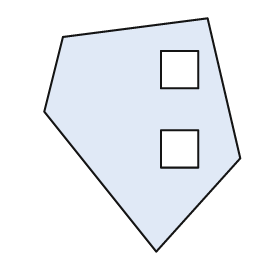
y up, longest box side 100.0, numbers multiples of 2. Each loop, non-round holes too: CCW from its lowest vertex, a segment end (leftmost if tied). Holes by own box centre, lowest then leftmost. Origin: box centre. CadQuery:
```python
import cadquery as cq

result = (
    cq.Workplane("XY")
    .moveTo(6.0, -50.0)
    .lineTo(42.0, -10.0)
    .lineTo(28.0, 50.0)
    .lineTo(-34.0, 42.0)
    .lineTo(-42.0, 10.0)
    .close()
    .moveTo(8.0, -14.0)
    .lineTo(24.0, -14.0)
    .lineTo(24.0, 2.0)
    .lineTo(8.0, 2.0)
    .close()
    .moveTo(8.0, 20.0)
    .lineTo(24.0, 20.0)
    .lineTo(24.0, 36.0)
    .lineTo(8.0, 36.0)
    .close()
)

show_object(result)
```